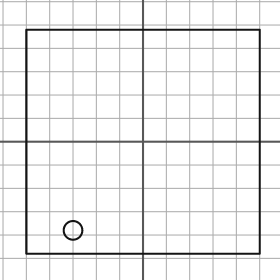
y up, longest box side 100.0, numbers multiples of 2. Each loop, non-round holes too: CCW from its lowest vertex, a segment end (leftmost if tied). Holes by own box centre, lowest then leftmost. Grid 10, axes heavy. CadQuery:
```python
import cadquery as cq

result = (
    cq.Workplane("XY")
    .moveTo(-50.0, -48.0)
    .lineTo(50.0, -48.0)
    .lineTo(50.0, 48.0)
    .lineTo(-50.0, 48.0)
    .close()
    .moveTo(-30.0, -38.0)
    .circle(4.0)
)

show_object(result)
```